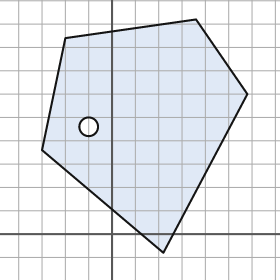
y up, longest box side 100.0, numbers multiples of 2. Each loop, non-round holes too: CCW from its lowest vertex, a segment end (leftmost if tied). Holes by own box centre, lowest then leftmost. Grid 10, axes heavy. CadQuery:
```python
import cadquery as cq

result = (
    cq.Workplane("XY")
    .moveTo(22.0, -8.0)
    .lineTo(58.0, 60.0)
    .lineTo(36.0, 92.0)
    .lineTo(-20.0, 84.0)
    .lineTo(-30.0, 36.0)
    .close()
    .moveTo(-10.0, 46.0)
    .circle(4.0)
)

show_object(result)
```